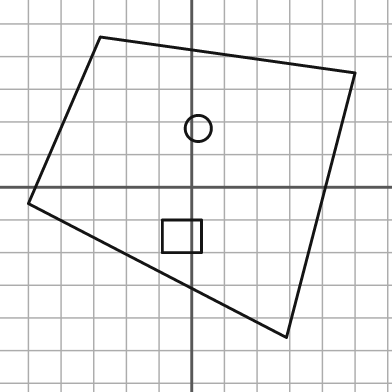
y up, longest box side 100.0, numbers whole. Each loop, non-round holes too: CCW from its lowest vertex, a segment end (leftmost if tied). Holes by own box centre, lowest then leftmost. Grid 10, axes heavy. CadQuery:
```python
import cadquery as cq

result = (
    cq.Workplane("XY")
    .moveTo(29.0, -46.0)
    .lineTo(50.0, 35.0)
    .lineTo(-28.0, 46.0)
    .lineTo(-50.0, -5.0)
    .close()
    .moveTo(-9.0, -20.0)
    .lineTo(3.0, -20.0)
    .lineTo(3.0, -10.0)
    .lineTo(-9.0, -10.0)
    .close()
    .moveTo(2.0, 18.0)
    .circle(4.0)
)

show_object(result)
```